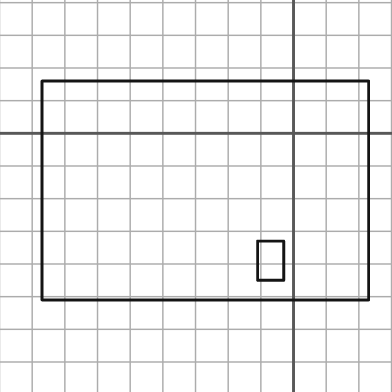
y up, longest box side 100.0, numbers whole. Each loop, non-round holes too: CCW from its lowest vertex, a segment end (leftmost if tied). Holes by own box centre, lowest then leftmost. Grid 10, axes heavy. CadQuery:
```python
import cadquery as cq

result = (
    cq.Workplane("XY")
    .moveTo(-77.0, -51.0)
    .lineTo(23.0, -51.0)
    .lineTo(23.0, 16.0)
    .lineTo(-77.0, 16.0)
    .close()
    .moveTo(-11.0, -45.0)
    .lineTo(-3.0, -45.0)
    .lineTo(-3.0, -33.0)
    .lineTo(-11.0, -33.0)
    .close()
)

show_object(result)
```